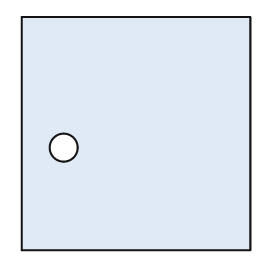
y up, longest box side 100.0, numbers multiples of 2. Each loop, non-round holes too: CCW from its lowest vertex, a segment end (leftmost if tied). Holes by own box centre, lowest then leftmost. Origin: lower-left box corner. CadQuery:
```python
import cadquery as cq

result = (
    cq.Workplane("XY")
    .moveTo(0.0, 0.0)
    .lineTo(98.0, 0.0)
    .lineTo(98.0, 100.0)
    .lineTo(0.0, 100.0)
    .close()
    .moveTo(18.0, 44.0)
    .circle(6.0)
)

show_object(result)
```